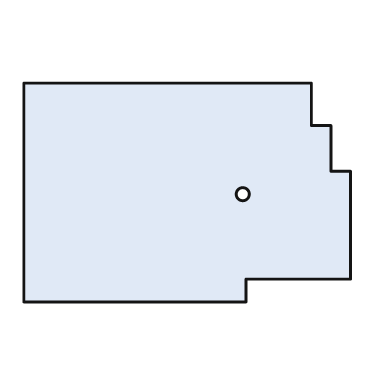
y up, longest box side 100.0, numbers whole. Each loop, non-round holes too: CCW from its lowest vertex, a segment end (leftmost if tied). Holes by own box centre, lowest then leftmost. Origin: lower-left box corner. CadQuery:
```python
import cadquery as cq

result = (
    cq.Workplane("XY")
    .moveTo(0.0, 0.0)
    .lineTo(68.0, 0.0)
    .lineTo(68.0, 7.0)
    .lineTo(100.0, 7.0)
    .lineTo(100.0, 40.0)
    .lineTo(94.0, 40.0)
    .lineTo(94.0, 54.0)
    .lineTo(88.0, 54.0)
    .lineTo(88.0, 67.0)
    .lineTo(0.0, 67.0)
    .close()
    .moveTo(67.0, 33.0)
    .circle(2.0)
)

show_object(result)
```